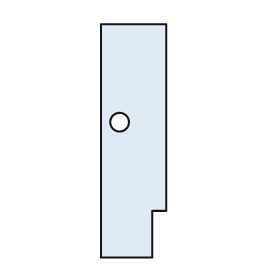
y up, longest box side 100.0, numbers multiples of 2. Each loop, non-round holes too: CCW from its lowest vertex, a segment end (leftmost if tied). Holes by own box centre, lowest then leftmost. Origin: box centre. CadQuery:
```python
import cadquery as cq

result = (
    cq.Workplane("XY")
    .moveTo(-14.0, -50.0)
    .lineTo(8.0, -50.0)
    .lineTo(8.0, -30.0)
    .lineTo(14.0, -30.0)
    .lineTo(14.0, 50.0)
    .lineTo(-14.0, 50.0)
    .close()
    .moveTo(-6.0, 8.0)
    .circle(4.0)
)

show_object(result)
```